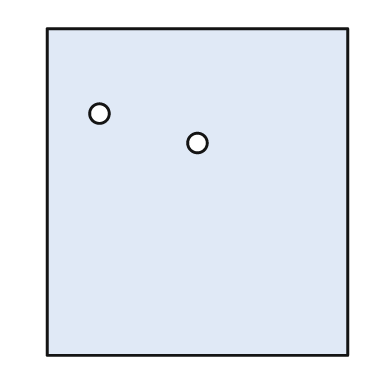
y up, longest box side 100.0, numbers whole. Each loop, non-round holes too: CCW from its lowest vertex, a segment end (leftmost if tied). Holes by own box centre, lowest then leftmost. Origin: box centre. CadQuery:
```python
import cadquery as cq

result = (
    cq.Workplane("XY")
    .moveTo(-46.0, -50.0)
    .lineTo(46.0, -50.0)
    .lineTo(46.0, 50.0)
    .lineTo(-46.0, 50.0)
    .close()
    .moveTo(0.0, 15.0)
    .circle(3.0)
    .moveTo(-30.0, 24.0)
    .circle(3.0)
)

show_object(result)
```